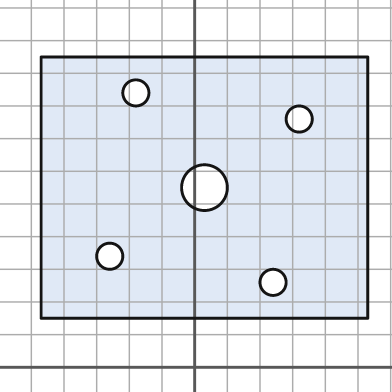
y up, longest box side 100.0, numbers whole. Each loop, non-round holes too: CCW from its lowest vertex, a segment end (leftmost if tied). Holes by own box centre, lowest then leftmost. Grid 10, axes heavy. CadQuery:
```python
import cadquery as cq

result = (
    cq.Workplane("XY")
    .moveTo(-47.0, 15.0)
    .lineTo(53.0, 15.0)
    .lineTo(53.0, 95.0)
    .lineTo(-47.0, 95.0)
    .close()
    .moveTo(24.0, 26.0)
    .circle(4.0)
    .moveTo(-26.0, 34.0)
    .circle(4.0)
    .moveTo(3.0, 55.0)
    .circle(7.0)
    .moveTo(32.0, 76.0)
    .circle(4.0)
    .moveTo(-18.0, 84.0)
    .circle(4.0)
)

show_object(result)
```